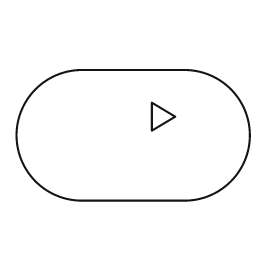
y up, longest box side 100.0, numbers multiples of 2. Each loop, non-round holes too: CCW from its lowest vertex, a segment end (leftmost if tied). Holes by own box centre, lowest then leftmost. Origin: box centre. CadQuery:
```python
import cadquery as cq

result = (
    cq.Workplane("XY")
    .moveTo(-22.0, -28.0)
    .lineTo(22.0, -28.0)
    .threePointArc((50.0, 0.0), (22.0, 28.0))
    .lineTo(-22.0, 28.0)
    .threePointArc((-50.0, 0.0), (-22.0, -28.0))
    .close()
    .moveTo(8.0, 2.0)
    .lineTo(18.0, 8.0)
    .lineTo(8.0, 14.0)
    .close()
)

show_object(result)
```